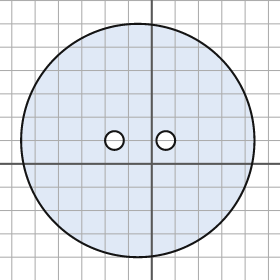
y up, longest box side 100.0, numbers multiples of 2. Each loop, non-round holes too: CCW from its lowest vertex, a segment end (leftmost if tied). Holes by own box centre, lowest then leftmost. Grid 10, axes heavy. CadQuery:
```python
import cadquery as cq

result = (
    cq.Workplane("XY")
    .moveTo(-6.0, 10.0)
    .circle(50.0)
    .moveTo(-16.0, 10.0)
    .circle(4.0)
    .moveTo(6.0, 10.0)
    .circle(4.0)
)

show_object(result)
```